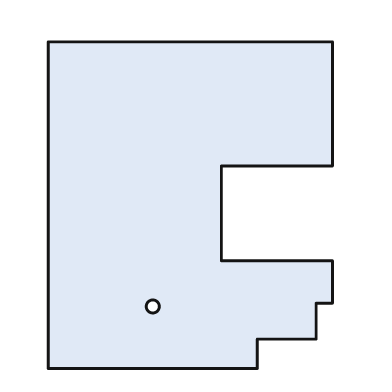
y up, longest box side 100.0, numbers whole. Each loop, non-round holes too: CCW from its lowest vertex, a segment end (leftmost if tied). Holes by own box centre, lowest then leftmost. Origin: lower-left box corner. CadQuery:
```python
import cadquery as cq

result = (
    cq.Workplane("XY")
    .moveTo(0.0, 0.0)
    .lineTo(64.0, 0.0)
    .lineTo(64.0, 9.0)
    .lineTo(82.0, 9.0)
    .lineTo(82.0, 20.0)
    .lineTo(87.0, 20.0)
    .lineTo(87.0, 33.0)
    .lineTo(53.0, 33.0)
    .lineTo(53.0, 62.0)
    .lineTo(87.0, 62.0)
    .lineTo(87.0, 100.0)
    .lineTo(0.0, 100.0)
    .close()
    .moveTo(32.0, 19.0)
    .circle(2.0)
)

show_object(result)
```